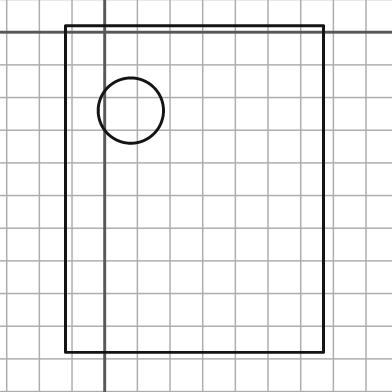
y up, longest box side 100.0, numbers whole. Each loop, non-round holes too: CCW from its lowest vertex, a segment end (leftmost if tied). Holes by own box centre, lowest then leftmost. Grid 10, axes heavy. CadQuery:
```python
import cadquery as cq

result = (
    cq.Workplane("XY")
    .moveTo(-12.0, -98.0)
    .lineTo(67.0, -98.0)
    .lineTo(67.0, 2.0)
    .lineTo(-12.0, 2.0)
    .close()
    .moveTo(8.0, -24.0)
    .circle(10.0)
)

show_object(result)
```